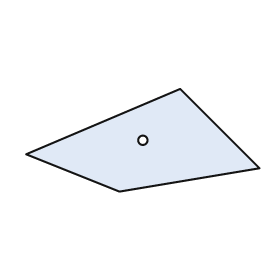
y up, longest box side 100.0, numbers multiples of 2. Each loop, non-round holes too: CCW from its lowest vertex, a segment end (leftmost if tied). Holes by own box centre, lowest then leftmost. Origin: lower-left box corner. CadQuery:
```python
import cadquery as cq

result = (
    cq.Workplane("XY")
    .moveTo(40.0, 0.0)
    .lineTo(100.0, 10.0)
    .lineTo(66.0, 44.0)
    .lineTo(0.0, 16.0)
    .close()
    .moveTo(50.0, 22.0)
    .circle(2.0)
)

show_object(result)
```